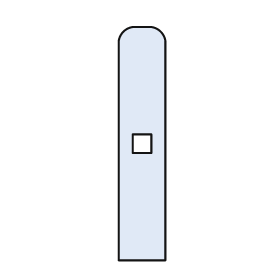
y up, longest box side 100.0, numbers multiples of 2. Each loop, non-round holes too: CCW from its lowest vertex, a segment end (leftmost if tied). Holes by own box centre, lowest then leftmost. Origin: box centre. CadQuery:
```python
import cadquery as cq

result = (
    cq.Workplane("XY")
    .moveTo(-10.0, -50.0)
    .lineTo(10.0, -50.0)
    .lineTo(10.0, 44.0)
    .threePointArc((8.0, 48.0), (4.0, 50.0))
    .lineTo(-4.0, 50.0)
    .threePointArc((-8.0, 48.0), (-10.0, 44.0))
    .close()
    .moveTo(-4.0, -4.0)
    .lineTo(4.0, -4.0)
    .lineTo(4.0, 4.0)
    .lineTo(-4.0, 4.0)
    .close()
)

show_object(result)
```